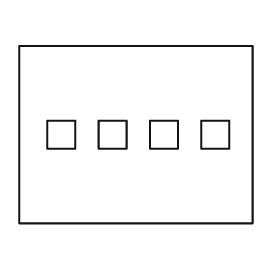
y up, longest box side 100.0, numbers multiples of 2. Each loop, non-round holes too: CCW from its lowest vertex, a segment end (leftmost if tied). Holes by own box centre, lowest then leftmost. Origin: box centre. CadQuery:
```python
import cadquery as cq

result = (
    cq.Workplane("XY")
    .moveTo(-50.0, -38.0)
    .lineTo(50.0, -38.0)
    .lineTo(50.0, 38.0)
    .lineTo(-50.0, 38.0)
    .close()
    .moveTo(-38.0, -6.0)
    .lineTo(-26.0, -6.0)
    .lineTo(-26.0, 6.0)
    .lineTo(-38.0, 6.0)
    .close()
    .moveTo(-16.0, -6.0)
    .lineTo(-4.0, -6.0)
    .lineTo(-4.0, 6.0)
    .lineTo(-16.0, 6.0)
    .close()
    .moveTo(6.0, -6.0)
    .lineTo(18.0, -6.0)
    .lineTo(18.0, 6.0)
    .lineTo(6.0, 6.0)
    .close()
    .moveTo(28.0, -6.0)
    .lineTo(40.0, -6.0)
    .lineTo(40.0, 6.0)
    .lineTo(28.0, 6.0)
    .close()
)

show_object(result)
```